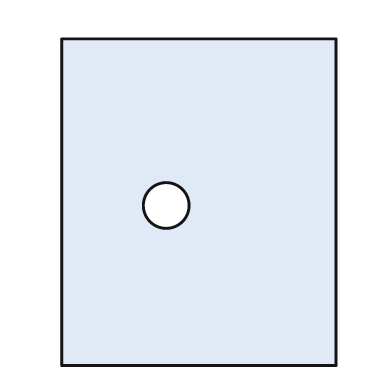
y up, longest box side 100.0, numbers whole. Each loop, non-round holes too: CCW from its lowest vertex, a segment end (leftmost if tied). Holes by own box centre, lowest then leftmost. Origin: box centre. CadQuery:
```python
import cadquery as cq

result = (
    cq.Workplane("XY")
    .moveTo(-42.0, -50.0)
    .lineTo(42.0, -50.0)
    .lineTo(42.0, 50.0)
    .lineTo(-42.0, 50.0)
    .close()
    .moveTo(-10.0, -1.0)
    .circle(7.0)
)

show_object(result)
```